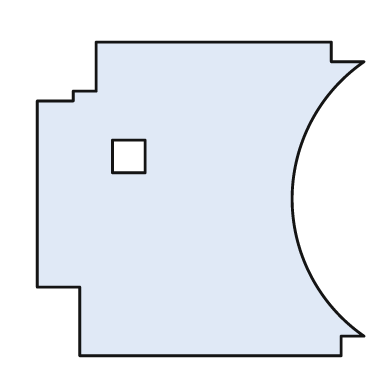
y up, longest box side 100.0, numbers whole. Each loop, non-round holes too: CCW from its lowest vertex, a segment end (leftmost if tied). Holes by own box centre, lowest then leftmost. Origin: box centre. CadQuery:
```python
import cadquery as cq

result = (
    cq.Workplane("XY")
    .moveTo(-37.0, -48.0)
    .lineTo(43.0, -48.0)
    .lineTo(43.0, -42.0)
    .lineTo(50.0, -42.0)
    .threePointArc((28.0, 0.0), (50.0, 42.0))
    .lineTo(40.0, 42.0)
    .lineTo(40.0, 48.0)
    .lineTo(-32.0, 48.0)
    .lineTo(-32.0, 33.0)
    .lineTo(-39.0, 33.0)
    .lineTo(-39.0, 30.0)
    .lineTo(-50.0, 30.0)
    .lineTo(-50.0, -27.0)
    .lineTo(-37.0, -27.0)
    .close()
    .moveTo(-27.0, 8.0)
    .lineTo(-17.0, 8.0)
    .lineTo(-17.0, 18.0)
    .lineTo(-27.0, 18.0)
    .close()
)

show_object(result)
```